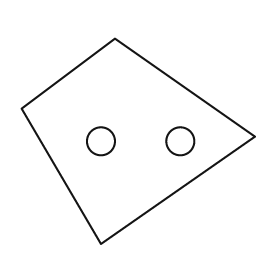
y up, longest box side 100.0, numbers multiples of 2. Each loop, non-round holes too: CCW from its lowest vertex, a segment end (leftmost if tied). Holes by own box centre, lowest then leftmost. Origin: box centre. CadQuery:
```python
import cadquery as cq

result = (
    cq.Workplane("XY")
    .moveTo(-16.0, -44.0)
    .lineTo(50.0, 2.0)
    .lineTo(-10.0, 44.0)
    .lineTo(-50.0, 14.0)
    .close()
    .moveTo(-16.0, 0.0)
    .circle(6.0)
    .moveTo(18.0, 0.0)
    .circle(6.0)
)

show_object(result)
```